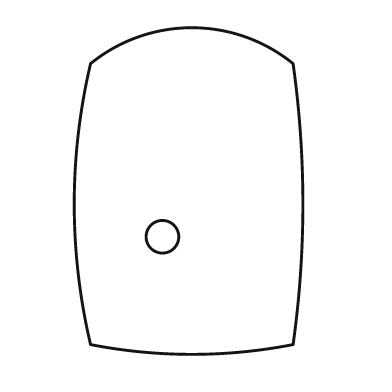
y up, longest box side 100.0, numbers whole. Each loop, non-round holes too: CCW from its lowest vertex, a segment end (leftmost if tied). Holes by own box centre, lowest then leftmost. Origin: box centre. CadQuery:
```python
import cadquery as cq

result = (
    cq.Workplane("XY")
    .moveTo(-30.0, -47.0)
    .threePointArc((1.0, -50.0), (32.0, -47.0))
    .threePointArc((35.0, -4.0), (32.0, 39.0))
    .threePointArc((1.0, 50.0), (-30.0, 39.0))
    .threePointArc((-35.0, -4.0), (-30.0, -47.0))
    .close()
    .moveTo(-8.0, -14.0)
    .circle(5.0)
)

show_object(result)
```